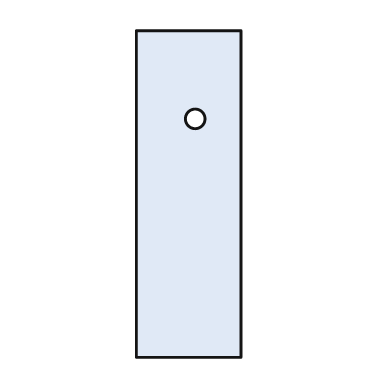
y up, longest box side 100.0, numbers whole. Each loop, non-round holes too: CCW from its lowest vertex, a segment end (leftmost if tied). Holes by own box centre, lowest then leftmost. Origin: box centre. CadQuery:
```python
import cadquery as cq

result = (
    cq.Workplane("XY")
    .moveTo(-16.0, -50.0)
    .lineTo(16.0, -50.0)
    .lineTo(16.0, 50.0)
    .lineTo(-16.0, 50.0)
    .close()
    .moveTo(2.0, 23.0)
    .circle(3.0)
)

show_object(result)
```